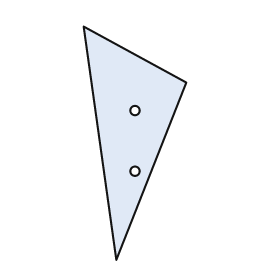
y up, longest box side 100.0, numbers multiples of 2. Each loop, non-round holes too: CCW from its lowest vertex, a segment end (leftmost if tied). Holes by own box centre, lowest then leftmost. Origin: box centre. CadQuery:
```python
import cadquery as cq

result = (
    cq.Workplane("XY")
    .moveTo(-8.0, -50.0)
    .lineTo(22.0, 26.0)
    .lineTo(-22.0, 50.0)
    .close()
    .moveTo(0.0, -12.0)
    .circle(2.0)
    .moveTo(0.0, 14.0)
    .circle(2.0)
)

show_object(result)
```